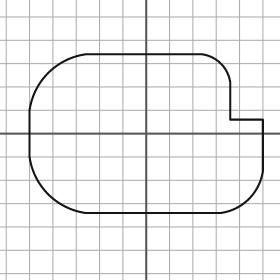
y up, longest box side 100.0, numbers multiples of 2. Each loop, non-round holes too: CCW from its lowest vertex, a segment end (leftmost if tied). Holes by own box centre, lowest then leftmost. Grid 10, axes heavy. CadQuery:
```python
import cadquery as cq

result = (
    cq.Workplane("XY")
    .moveTo(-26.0, -34.0)
    .lineTo(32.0, -34.0)
    .threePointArc((44.0, -28.0), (50.0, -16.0))
    .lineTo(50.0, 6.0)
    .lineTo(36.0, 6.0)
    .lineTo(36.0, 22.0)
    .threePointArc((32.0, 30.0), (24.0, 34.0))
    .lineTo(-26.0, 34.0)
    .threePointArc((-42.0, 26.0), (-50.0, 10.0))
    .lineTo(-50.0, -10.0)
    .threePointArc((-42.0, -26.0), (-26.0, -34.0))
    .close()
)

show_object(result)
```